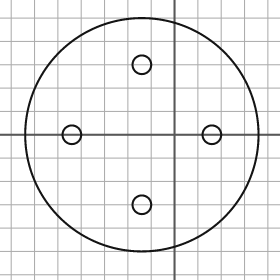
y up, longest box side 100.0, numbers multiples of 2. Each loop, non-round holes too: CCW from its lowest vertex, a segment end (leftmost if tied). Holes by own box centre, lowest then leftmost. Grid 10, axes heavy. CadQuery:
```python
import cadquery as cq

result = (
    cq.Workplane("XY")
    .moveTo(-14.0, 0.0)
    .circle(50.0)
    .moveTo(-14.0, -30.0)
    .circle(4.0)
    .moveTo(-44.0, 0.0)
    .circle(4.0)
    .moveTo(16.0, 0.0)
    .circle(4.0)
    .moveTo(-14.0, 30.0)
    .circle(4.0)
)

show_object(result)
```